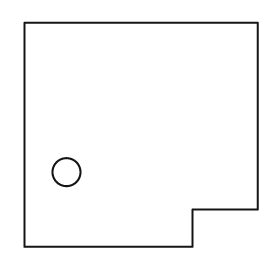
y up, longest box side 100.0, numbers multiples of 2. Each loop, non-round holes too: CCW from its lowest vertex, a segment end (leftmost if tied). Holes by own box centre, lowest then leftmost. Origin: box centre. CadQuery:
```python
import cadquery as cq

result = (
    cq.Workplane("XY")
    .moveTo(-50.0, -48.0)
    .lineTo(22.0, -48.0)
    .lineTo(22.0, -32.0)
    .lineTo(50.0, -32.0)
    .lineTo(50.0, 48.0)
    .lineTo(-50.0, 48.0)
    .close()
    .moveTo(-32.0, -16.0)
    .circle(6.0)
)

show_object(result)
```